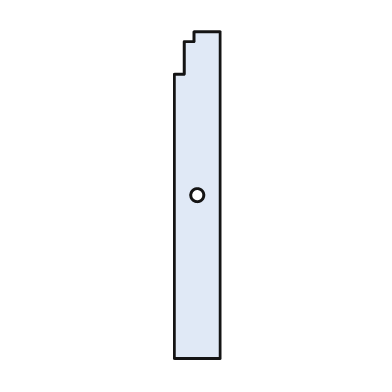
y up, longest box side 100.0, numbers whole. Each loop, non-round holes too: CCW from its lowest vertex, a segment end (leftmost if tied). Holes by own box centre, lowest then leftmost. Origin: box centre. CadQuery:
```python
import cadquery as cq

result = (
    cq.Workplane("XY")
    .moveTo(-7.0, -50.0)
    .lineTo(7.0, -50.0)
    .lineTo(7.0, 50.0)
    .lineTo(-1.0, 50.0)
    .lineTo(-1.0, 47.0)
    .lineTo(-4.0, 47.0)
    .lineTo(-4.0, 37.0)
    .lineTo(-7.0, 37.0)
    .close()
    .moveTo(0.0, 0.0)
    .circle(2.0)
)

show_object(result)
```